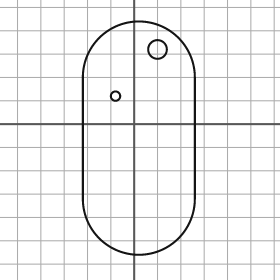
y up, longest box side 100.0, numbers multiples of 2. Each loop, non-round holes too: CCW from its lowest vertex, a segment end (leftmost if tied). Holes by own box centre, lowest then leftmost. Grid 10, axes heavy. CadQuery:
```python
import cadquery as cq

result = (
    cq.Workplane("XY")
    .moveTo(-22.0, -32.0)
    .threePointArc((2.0, -56.0), (26.0, -32.0))
    .lineTo(26.0, 20.0)
    .threePointArc((2.0, 44.0), (-22.0, 20.0))
    .close()
    .moveTo(-8.0, 12.0)
    .circle(2.0)
    .moveTo(10.0, 32.0)
    .circle(4.0)
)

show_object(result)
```